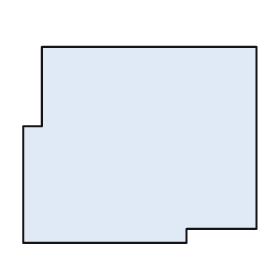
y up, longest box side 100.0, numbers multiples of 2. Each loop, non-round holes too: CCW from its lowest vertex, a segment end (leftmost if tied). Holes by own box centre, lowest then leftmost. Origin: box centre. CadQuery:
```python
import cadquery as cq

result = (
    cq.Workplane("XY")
    .moveTo(-50.0, -42.0)
    .lineTo(20.0, -42.0)
    .lineTo(20.0, -36.0)
    .lineTo(50.0, -36.0)
    .lineTo(50.0, 42.0)
    .lineTo(-42.0, 42.0)
    .lineTo(-42.0, 8.0)
    .lineTo(-50.0, 8.0)
    .close()
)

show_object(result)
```